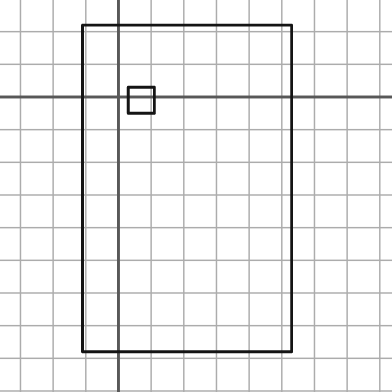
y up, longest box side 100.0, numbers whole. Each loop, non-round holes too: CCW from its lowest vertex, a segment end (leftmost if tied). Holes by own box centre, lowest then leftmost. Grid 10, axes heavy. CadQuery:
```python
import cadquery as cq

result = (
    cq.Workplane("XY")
    .moveTo(-11.0, -78.0)
    .lineTo(53.0, -78.0)
    .lineTo(53.0, 22.0)
    .lineTo(-11.0, 22.0)
    .close()
    .moveTo(3.0, -5.0)
    .lineTo(11.0, -5.0)
    .lineTo(11.0, 3.0)
    .lineTo(3.0, 3.0)
    .close()
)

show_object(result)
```